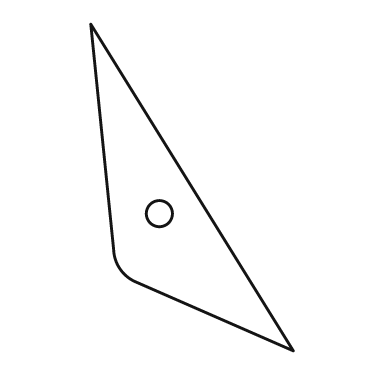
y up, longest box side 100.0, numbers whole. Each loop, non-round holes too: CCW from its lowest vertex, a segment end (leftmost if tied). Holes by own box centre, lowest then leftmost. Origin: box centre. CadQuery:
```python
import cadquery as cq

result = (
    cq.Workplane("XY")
    .moveTo(31.0, -50.0)
    .lineTo(-31.0, 50.0)
    .lineTo(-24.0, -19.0)
    .threePointArc((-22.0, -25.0), (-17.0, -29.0))
    .close()
    .moveTo(-10.0, -8.0)
    .circle(4.0)
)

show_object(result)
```